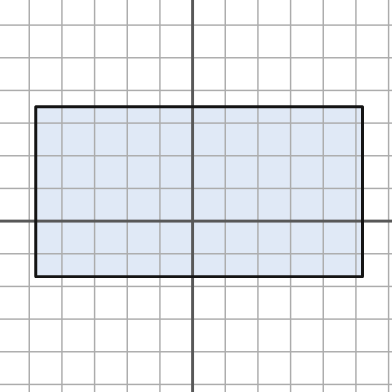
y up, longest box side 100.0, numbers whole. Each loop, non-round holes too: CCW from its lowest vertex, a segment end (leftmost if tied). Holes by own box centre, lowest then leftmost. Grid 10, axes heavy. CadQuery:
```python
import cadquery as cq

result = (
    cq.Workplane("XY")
    .moveTo(-48.0, -17.0)
    .lineTo(52.0, -17.0)
    .lineTo(52.0, 35.0)
    .lineTo(-48.0, 35.0)
    .close()
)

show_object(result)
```